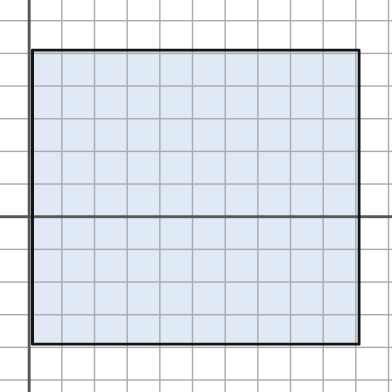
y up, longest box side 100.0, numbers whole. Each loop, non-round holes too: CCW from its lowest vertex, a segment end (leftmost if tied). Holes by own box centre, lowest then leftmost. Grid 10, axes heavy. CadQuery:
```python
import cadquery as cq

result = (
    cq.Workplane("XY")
    .moveTo(1.0, -39.0)
    .lineTo(101.0, -39.0)
    .lineTo(101.0, 51.0)
    .lineTo(1.0, 51.0)
    .close()
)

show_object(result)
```